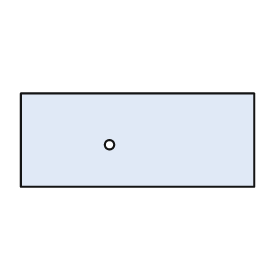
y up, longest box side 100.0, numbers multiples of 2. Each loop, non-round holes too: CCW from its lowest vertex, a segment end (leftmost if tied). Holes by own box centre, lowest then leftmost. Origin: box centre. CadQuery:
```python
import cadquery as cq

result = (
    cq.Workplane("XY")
    .moveTo(-50.0, -20.0)
    .lineTo(50.0, -20.0)
    .lineTo(50.0, 20.0)
    .lineTo(-50.0, 20.0)
    .close()
    .moveTo(-12.0, -2.0)
    .circle(2.0)
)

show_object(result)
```